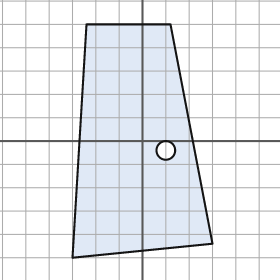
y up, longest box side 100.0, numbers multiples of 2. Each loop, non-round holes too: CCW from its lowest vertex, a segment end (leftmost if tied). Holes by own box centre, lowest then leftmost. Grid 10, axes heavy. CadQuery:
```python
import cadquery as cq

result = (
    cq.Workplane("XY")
    .moveTo(-30.0, -50.0)
    .lineTo(30.0, -44.0)
    .lineTo(12.0, 50.0)
    .lineTo(-24.0, 50.0)
    .close()
    .moveTo(10.0, -4.0)
    .circle(4.0)
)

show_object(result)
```